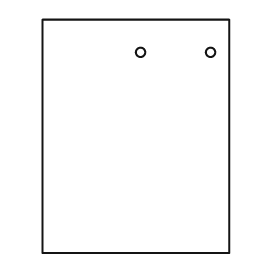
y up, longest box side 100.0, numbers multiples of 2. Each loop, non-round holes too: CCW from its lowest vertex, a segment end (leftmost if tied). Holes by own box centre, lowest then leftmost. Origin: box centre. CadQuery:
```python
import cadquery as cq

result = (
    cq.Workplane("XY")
    .moveTo(-40.0, -50.0)
    .lineTo(40.0, -50.0)
    .lineTo(40.0, 50.0)
    .lineTo(-40.0, 50.0)
    .close()
    .moveTo(2.0, 36.0)
    .circle(2.0)
    .moveTo(32.0, 36.0)
    .circle(2.0)
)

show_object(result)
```